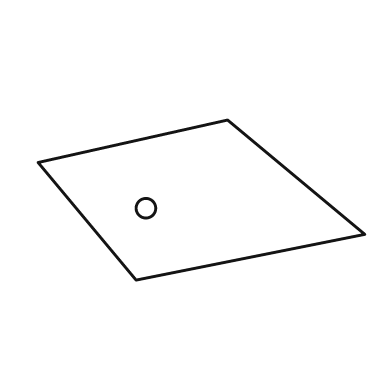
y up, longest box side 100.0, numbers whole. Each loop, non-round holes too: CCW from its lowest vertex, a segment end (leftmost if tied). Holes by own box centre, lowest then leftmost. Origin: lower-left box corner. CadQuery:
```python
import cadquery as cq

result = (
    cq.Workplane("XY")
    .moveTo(30.0, 0.0)
    .lineTo(100.0, 14.0)
    .lineTo(58.0, 49.0)
    .lineTo(0.0, 36.0)
    .close()
    .moveTo(33.0, 22.0)
    .circle(3.0)
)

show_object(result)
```